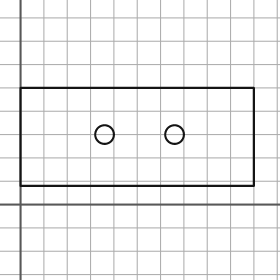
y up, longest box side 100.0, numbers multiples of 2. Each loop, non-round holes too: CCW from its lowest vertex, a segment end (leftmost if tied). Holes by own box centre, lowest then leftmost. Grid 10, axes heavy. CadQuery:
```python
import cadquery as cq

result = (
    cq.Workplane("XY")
    .moveTo(0.0, 8.0)
    .lineTo(100.0, 8.0)
    .lineTo(100.0, 50.0)
    .lineTo(0.0, 50.0)
    .close()
    .moveTo(36.0, 30.0)
    .circle(4.0)
    .moveTo(66.0, 30.0)
    .circle(4.0)
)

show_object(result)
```